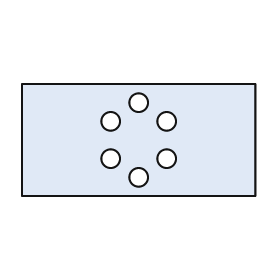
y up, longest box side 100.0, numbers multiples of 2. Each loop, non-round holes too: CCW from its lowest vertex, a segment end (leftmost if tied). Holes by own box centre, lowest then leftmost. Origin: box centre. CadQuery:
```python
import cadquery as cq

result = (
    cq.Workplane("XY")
    .moveTo(-50.0, -24.0)
    .lineTo(50.0, -24.0)
    .lineTo(50.0, 24.0)
    .lineTo(-50.0, 24.0)
    .close()
    .moveTo(0.0, -16.0)
    .circle(4.0)
    .moveTo(-12.0, -8.0)
    .circle(4.0)
    .moveTo(12.0, -8.0)
    .circle(4.0)
    .moveTo(-12.0, 8.0)
    .circle(4.0)
    .moveTo(12.0, 8.0)
    .circle(4.0)
    .moveTo(0.0, 16.0)
    .circle(4.0)
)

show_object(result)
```